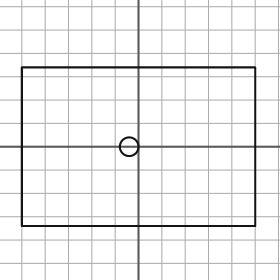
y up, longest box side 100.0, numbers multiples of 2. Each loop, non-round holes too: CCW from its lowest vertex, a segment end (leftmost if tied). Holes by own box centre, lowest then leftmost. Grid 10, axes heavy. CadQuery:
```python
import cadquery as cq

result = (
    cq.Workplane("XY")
    .moveTo(-50.0, -34.0)
    .lineTo(50.0, -34.0)
    .lineTo(50.0, 34.0)
    .lineTo(-50.0, 34.0)
    .close()
    .moveTo(-4.0, 0.0)
    .circle(4.0)
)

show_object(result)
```